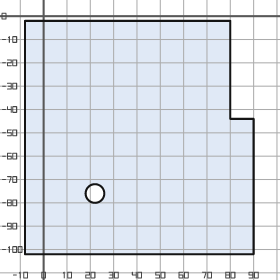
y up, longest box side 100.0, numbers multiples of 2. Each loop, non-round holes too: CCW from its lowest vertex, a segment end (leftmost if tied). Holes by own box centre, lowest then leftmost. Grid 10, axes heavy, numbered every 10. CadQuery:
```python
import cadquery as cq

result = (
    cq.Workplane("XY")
    .moveTo(-8.0, -102.0)
    .lineTo(90.0, -102.0)
    .lineTo(90.0, -44.0)
    .lineTo(80.0, -44.0)
    .lineTo(80.0, -2.0)
    .lineTo(-8.0, -2.0)
    .close()
    .moveTo(22.0, -76.0)
    .circle(4.0)
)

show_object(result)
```